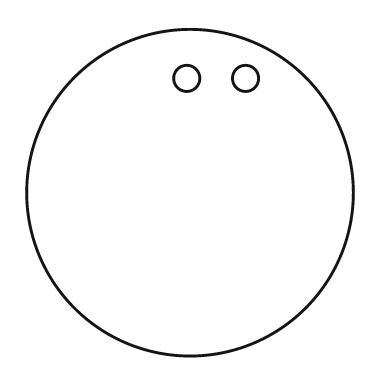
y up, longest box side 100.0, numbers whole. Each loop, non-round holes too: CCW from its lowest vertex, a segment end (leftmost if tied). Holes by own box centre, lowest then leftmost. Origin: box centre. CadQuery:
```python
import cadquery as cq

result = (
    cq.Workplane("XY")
    .moveTo(0.0, 0.0)
    .circle(50.0)
    .moveTo(-1.0, 35.0)
    .circle(4.0)
    .moveTo(17.0, 35.0)
    .circle(4.0)
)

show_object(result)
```